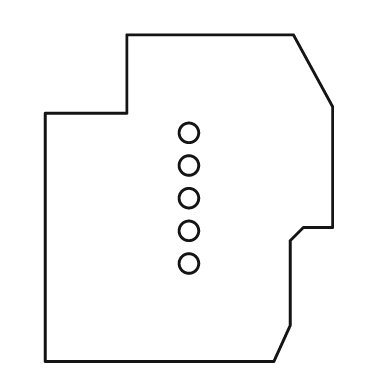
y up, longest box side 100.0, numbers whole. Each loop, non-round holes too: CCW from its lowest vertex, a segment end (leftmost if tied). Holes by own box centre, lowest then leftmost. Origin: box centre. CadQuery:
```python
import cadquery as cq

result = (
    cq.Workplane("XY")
    .moveTo(-44.0, -50.0)
    .lineTo(26.0, -50.0)
    .lineTo(31.0, -39.0)
    .lineTo(31.0, -13.0)
    .lineTo(35.0, -9.0)
    .lineTo(44.0, -9.0)
    .lineTo(44.0, 28.0)
    .lineTo(32.0, 50.0)
    .lineTo(-19.0, 50.0)
    .lineTo(-19.0, 26.0)
    .lineTo(-44.0, 26.0)
    .close()
    .moveTo(0.0, -20.0)
    .circle(3.0)
    .moveTo(0.0, -10.0)
    .circle(3.0)
    .moveTo(0.0, 0.0)
    .circle(3.0)
    .moveTo(0.0, 10.0)
    .circle(3.0)
    .moveTo(0.0, 20.0)
    .circle(3.0)
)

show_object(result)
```